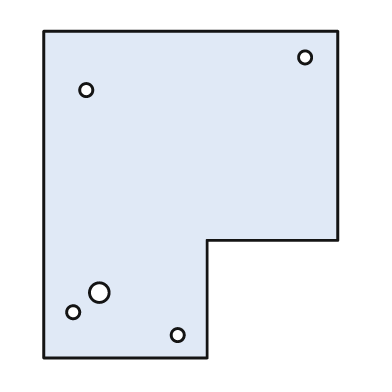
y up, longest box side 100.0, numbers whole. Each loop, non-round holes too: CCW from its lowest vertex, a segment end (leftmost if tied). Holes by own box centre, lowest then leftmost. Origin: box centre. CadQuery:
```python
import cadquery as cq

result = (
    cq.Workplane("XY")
    .moveTo(-45.0, -50.0)
    .lineTo(5.0, -50.0)
    .lineTo(5.0, -14.0)
    .lineTo(45.0, -14.0)
    .lineTo(45.0, 50.0)
    .lineTo(-45.0, 50.0)
    .close()
    .moveTo(-4.0, -43.0)
    .circle(2.0)
    .moveTo(-36.0, -36.0)
    .circle(2.0)
    .moveTo(-28.0, -30.0)
    .circle(3.0)
    .moveTo(-32.0, 32.0)
    .circle(2.0)
    .moveTo(35.0, 42.0)
    .circle(2.0)
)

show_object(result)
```